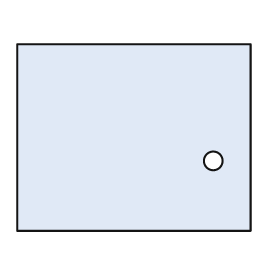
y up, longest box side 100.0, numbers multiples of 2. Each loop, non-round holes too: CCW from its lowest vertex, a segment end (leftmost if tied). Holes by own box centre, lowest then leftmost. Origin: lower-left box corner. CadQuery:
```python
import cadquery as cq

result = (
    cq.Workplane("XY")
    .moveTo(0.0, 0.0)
    .lineTo(100.0, 0.0)
    .lineTo(100.0, 80.0)
    .lineTo(0.0, 80.0)
    .close()
    .moveTo(84.0, 30.0)
    .circle(4.0)
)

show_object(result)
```